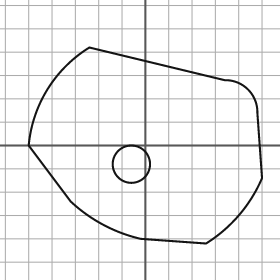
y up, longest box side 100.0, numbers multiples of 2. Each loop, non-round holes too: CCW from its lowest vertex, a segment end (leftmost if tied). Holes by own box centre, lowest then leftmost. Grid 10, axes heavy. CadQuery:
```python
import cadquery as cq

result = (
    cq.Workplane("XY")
    .moveTo(26.0, -42.0)
    .threePointArc((40.0, -30.0), (50.0, -14.0))
    .lineTo(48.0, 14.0)
    .threePointArc((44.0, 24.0), (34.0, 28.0))
    .lineTo(-24.0, 42.0)
    .threePointArc((-42.0, 24.0), (-50.0, 0.0))
    .lineTo(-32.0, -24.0)
    .threePointArc((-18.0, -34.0), (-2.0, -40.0))
    .close()
    .moveTo(-6.0, -8.0)
    .circle(8.0)
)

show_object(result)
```